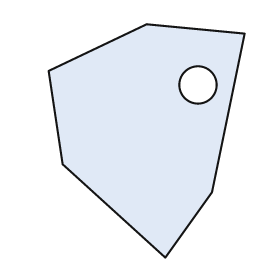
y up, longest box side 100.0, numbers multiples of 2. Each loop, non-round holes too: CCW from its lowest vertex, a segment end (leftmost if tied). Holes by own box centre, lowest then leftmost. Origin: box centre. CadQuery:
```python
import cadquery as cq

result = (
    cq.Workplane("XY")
    .moveTo(8.0, -50.0)
    .lineTo(28.0, -22.0)
    .lineTo(42.0, 46.0)
    .lineTo(0.0, 50.0)
    .lineTo(-42.0, 30.0)
    .lineTo(-36.0, -10.0)
    .close()
    .moveTo(22.0, 24.0)
    .circle(8.0)
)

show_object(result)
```